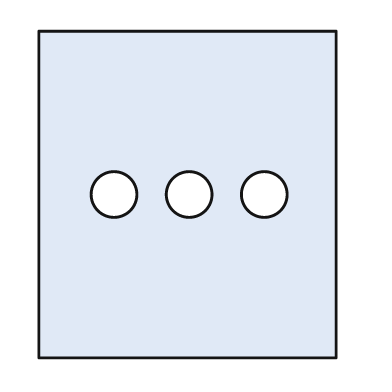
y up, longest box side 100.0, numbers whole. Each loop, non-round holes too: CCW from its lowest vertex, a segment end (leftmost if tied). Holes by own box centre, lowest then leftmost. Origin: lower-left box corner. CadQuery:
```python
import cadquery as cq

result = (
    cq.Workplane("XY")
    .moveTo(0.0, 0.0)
    .lineTo(91.0, 0.0)
    .lineTo(91.0, 100.0)
    .lineTo(0.0, 100.0)
    .close()
    .moveTo(23.0, 50.0)
    .circle(7.0)
    .moveTo(46.0, 50.0)
    .circle(7.0)
    .moveTo(69.0, 50.0)
    .circle(7.0)
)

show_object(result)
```